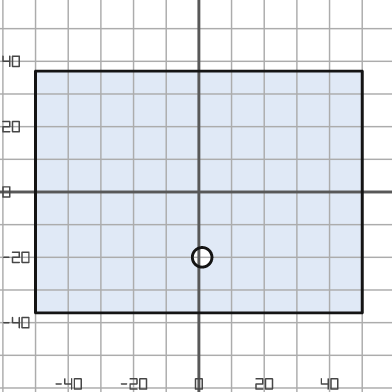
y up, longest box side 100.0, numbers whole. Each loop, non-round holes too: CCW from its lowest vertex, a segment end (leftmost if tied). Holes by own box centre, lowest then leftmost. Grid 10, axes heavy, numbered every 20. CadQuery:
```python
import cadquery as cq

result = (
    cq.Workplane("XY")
    .moveTo(-50.0, -37.0)
    .lineTo(50.0, -37.0)
    .lineTo(50.0, 37.0)
    .lineTo(-50.0, 37.0)
    .close()
    .moveTo(1.0, -20.0)
    .circle(3.0)
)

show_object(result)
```